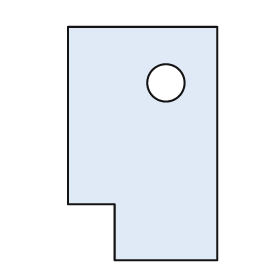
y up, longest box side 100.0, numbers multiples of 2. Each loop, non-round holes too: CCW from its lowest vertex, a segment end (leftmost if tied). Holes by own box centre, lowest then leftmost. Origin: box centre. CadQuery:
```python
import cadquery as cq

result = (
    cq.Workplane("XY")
    .moveTo(-12.0, -50.0)
    .lineTo(32.0, -50.0)
    .lineTo(32.0, 50.0)
    .lineTo(-32.0, 50.0)
    .lineTo(-32.0, -26.0)
    .lineTo(-12.0, -26.0)
    .close()
    .moveTo(10.0, 26.0)
    .circle(8.0)
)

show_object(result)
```